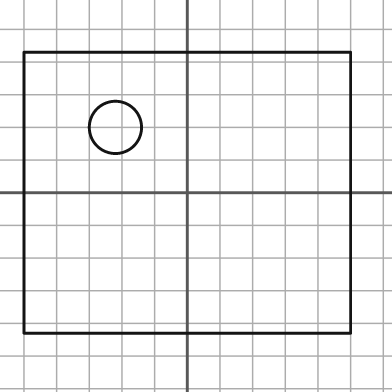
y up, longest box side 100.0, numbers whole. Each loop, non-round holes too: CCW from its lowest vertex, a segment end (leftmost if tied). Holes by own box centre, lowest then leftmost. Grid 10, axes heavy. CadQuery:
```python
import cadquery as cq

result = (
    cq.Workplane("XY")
    .moveTo(-50.0, -43.0)
    .lineTo(50.0, -43.0)
    .lineTo(50.0, 43.0)
    .lineTo(-50.0, 43.0)
    .close()
    .moveTo(-22.0, 20.0)
    .circle(8.0)
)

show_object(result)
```